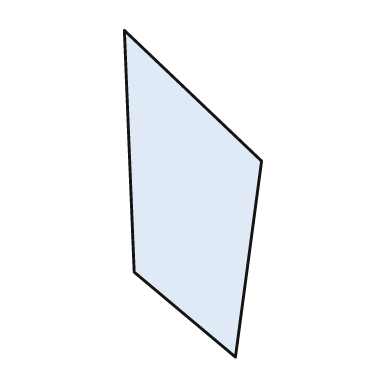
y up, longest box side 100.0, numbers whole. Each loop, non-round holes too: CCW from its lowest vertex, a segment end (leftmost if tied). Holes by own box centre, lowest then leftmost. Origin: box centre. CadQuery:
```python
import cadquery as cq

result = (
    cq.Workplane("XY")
    .moveTo(13.0, -50.0)
    .lineTo(21.0, 10.0)
    .lineTo(-21.0, 50.0)
    .lineTo(-18.0, -24.0)
    .close()
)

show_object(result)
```